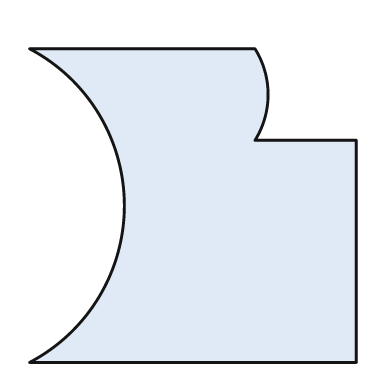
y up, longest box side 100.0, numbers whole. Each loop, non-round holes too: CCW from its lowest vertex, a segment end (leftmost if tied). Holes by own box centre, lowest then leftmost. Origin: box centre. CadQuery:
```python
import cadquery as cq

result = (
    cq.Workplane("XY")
    .moveTo(-50.0, -48.0)
    .lineTo(50.0, -48.0)
    .lineTo(50.0, 20.0)
    .lineTo(19.0, 20.0)
    .threePointArc((23.0, 34.0), (19.0, 48.0))
    .lineTo(-50.0, 48.0)
    .threePointArc((-21.0, 0.0), (-50.0, -48.0))
    .close()
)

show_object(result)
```